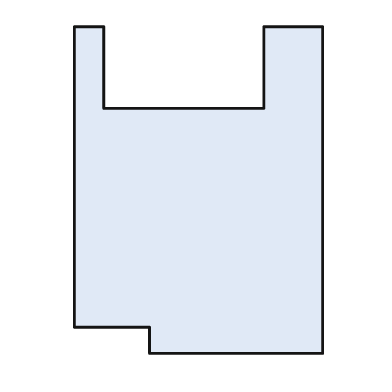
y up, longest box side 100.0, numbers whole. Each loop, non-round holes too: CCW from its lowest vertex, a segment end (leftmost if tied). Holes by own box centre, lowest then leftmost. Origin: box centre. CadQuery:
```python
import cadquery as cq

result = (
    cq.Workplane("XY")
    .moveTo(-15.0, -50.0)
    .lineTo(38.0, -50.0)
    .lineTo(38.0, 50.0)
    .lineTo(20.0, 50.0)
    .lineTo(20.0, 25.0)
    .lineTo(-29.0, 25.0)
    .lineTo(-29.0, 50.0)
    .lineTo(-38.0, 50.0)
    .lineTo(-38.0, -42.0)
    .lineTo(-15.0, -42.0)
    .close()
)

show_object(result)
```